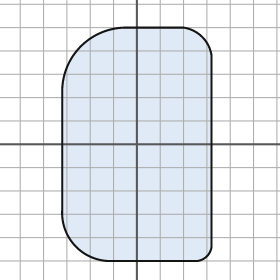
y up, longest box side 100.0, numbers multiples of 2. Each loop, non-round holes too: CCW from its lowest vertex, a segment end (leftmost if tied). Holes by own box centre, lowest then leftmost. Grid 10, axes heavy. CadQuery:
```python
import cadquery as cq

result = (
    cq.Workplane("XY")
    .moveTo(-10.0, -50.0)
    .lineTo(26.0, -50.0)
    .threePointArc((30.0, -48.0), (32.0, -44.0))
    .lineTo(32.0, 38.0)
    .threePointArc((28.0, 46.0), (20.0, 50.0))
    .lineTo(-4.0, 50.0)
    .threePointArc((-24.0, 42.0), (-32.0, 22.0))
    .lineTo(-32.0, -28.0)
    .threePointArc((-26.0, -44.0), (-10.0, -50.0))
    .close()
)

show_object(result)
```